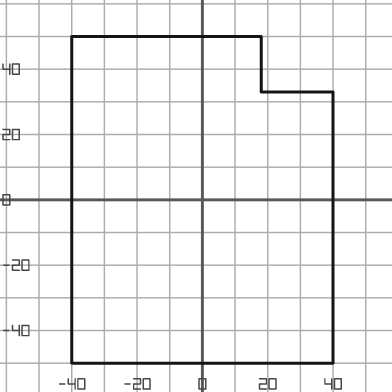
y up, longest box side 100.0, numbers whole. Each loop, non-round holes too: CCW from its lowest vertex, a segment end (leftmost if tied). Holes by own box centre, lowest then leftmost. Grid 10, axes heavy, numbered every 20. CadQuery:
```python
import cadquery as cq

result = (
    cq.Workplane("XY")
    .moveTo(-40.0, -50.0)
    .lineTo(40.0, -50.0)
    .lineTo(40.0, 33.0)
    .lineTo(18.0, 33.0)
    .lineTo(18.0, 50.0)
    .lineTo(-40.0, 50.0)
    .close()
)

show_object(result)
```